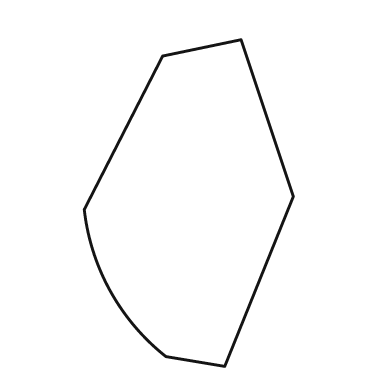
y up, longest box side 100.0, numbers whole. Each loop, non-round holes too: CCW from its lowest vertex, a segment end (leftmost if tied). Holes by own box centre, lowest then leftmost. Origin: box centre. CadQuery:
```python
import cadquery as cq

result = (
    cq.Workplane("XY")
    .moveTo(11.0, -50.0)
    .lineTo(32.0, 2.0)
    .lineTo(16.0, 50.0)
    .lineTo(-8.0, 45.0)
    .lineTo(-32.0, -2.0)
    .threePointArc((-24.0, -27.0), (-7.0, -47.0))
    .close()
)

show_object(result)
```